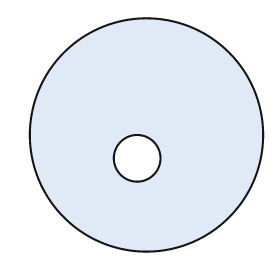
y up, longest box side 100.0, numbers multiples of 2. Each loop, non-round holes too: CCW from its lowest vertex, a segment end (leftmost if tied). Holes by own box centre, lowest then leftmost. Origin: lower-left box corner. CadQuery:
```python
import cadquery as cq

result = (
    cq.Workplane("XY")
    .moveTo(50.0, 50.0)
    .circle(50.0)
    .moveTo(46.0, 40.0)
    .circle(10.0)
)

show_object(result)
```